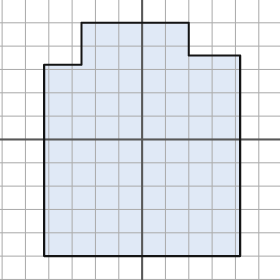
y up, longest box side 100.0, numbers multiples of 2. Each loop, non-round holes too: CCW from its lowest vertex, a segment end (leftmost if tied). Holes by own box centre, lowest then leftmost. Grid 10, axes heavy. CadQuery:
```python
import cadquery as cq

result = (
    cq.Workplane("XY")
    .moveTo(-42.0, -50.0)
    .lineTo(42.0, -50.0)
    .lineTo(42.0, 36.0)
    .lineTo(20.0, 36.0)
    .lineTo(20.0, 50.0)
    .lineTo(-26.0, 50.0)
    .lineTo(-26.0, 32.0)
    .lineTo(-42.0, 32.0)
    .close()
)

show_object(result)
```